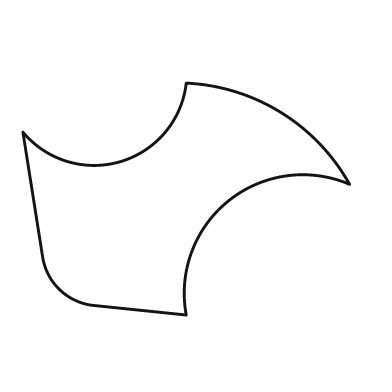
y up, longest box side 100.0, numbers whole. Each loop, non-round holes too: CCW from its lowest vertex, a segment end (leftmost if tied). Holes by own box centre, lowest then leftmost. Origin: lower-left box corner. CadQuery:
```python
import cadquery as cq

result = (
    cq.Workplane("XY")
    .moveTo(50.0, 0.0)
    .threePointArc((63.0, 35.0), (100.0, 40.0))
    .threePointArc((79.0, 62.0), (50.0, 71.0))
    .threePointArc((30.0, 47.0), (0.0, 56.0))
    .lineTo(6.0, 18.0)
    .threePointArc((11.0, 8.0), (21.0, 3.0))
    .close()
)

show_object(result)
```